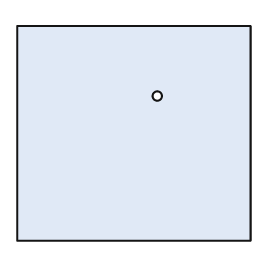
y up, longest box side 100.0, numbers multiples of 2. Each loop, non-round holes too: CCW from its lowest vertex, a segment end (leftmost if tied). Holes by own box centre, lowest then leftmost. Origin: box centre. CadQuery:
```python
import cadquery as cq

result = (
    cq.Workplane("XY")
    .moveTo(-50.0, -46.0)
    .lineTo(50.0, -46.0)
    .lineTo(50.0, 46.0)
    .lineTo(-50.0, 46.0)
    .close()
    .moveTo(10.0, 16.0)
    .circle(2.0)
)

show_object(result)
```